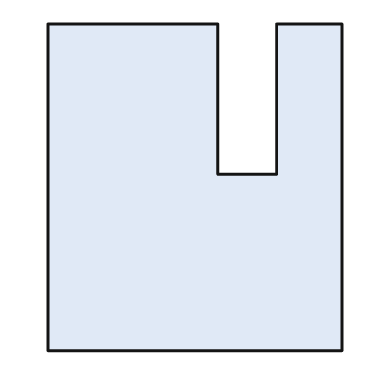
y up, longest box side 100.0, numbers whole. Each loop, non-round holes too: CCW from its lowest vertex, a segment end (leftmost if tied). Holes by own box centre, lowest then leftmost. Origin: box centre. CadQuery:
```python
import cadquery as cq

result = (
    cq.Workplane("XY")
    .moveTo(-45.0, -50.0)
    .lineTo(45.0, -50.0)
    .lineTo(45.0, 50.0)
    .lineTo(25.0, 50.0)
    .lineTo(25.0, 4.0)
    .lineTo(7.0, 4.0)
    .lineTo(7.0, 50.0)
    .lineTo(-45.0, 50.0)
    .close()
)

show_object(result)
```